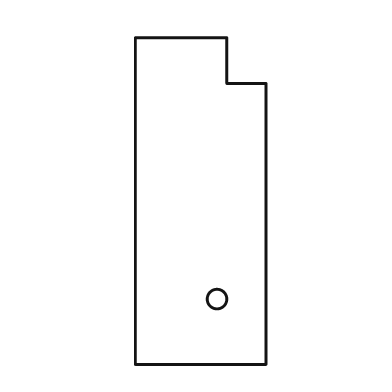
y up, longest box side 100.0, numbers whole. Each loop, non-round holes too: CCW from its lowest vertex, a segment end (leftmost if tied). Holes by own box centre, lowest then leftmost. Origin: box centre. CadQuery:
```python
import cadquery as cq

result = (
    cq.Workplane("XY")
    .moveTo(-20.0, -50.0)
    .lineTo(20.0, -50.0)
    .lineTo(20.0, 36.0)
    .lineTo(8.0, 36.0)
    .lineTo(8.0, 50.0)
    .lineTo(-20.0, 50.0)
    .close()
    .moveTo(5.0, -30.0)
    .circle(3.0)
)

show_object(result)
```